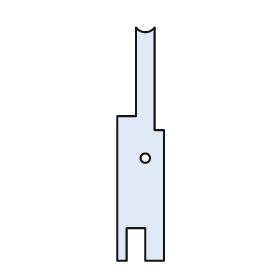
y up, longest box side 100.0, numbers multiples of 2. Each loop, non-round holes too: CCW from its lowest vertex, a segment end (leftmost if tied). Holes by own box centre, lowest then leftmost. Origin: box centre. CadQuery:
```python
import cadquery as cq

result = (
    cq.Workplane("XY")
    .moveTo(-10.0, -50.0)
    .lineTo(-6.0, -50.0)
    .lineTo(-6.0, -36.0)
    .lineTo(2.0, -36.0)
    .lineTo(2.0, -50.0)
    .lineTo(10.0, -50.0)
    .lineTo(10.0, 6.0)
    .lineTo(6.0, 6.0)
    .lineTo(6.0, 50.0)
    .threePointArc((2.0, 48.0), (-2.0, 50.0))
    .lineTo(-2.0, 12.0)
    .lineTo(-10.0, 12.0)
    .close()
    .moveTo(2.0, -6.0)
    .circle(2.0)
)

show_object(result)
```